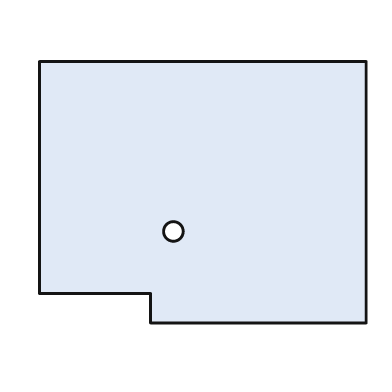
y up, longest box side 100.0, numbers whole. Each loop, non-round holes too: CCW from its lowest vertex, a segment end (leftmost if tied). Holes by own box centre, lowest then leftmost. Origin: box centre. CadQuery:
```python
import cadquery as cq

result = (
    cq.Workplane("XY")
    .moveTo(-16.0, -40.0)
    .lineTo(50.0, -40.0)
    .lineTo(50.0, 40.0)
    .lineTo(-50.0, 40.0)
    .lineTo(-50.0, -31.0)
    .lineTo(-16.0, -31.0)
    .close()
    .moveTo(-9.0, -12.0)
    .circle(3.0)
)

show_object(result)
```